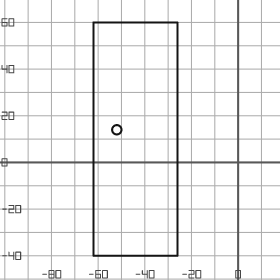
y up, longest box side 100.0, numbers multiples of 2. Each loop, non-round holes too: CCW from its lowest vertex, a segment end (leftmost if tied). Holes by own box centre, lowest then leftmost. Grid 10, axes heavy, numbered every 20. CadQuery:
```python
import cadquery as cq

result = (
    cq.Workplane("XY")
    .moveTo(-62.0, -40.0)
    .lineTo(-26.0, -40.0)
    .lineTo(-26.0, 60.0)
    .lineTo(-62.0, 60.0)
    .close()
    .moveTo(-52.0, 14.0)
    .circle(2.0)
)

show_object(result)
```